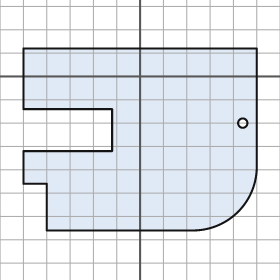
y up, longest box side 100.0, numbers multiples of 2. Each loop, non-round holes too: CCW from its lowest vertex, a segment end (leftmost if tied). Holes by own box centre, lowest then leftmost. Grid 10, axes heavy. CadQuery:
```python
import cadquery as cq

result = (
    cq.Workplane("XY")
    .moveTo(-40.0, -66.0)
    .lineTo(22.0, -66.0)
    .threePointArc((42.0, -58.0), (50.0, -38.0))
    .lineTo(50.0, 12.0)
    .lineTo(-50.0, 12.0)
    .lineTo(-50.0, -14.0)
    .lineTo(-12.0, -14.0)
    .lineTo(-12.0, -32.0)
    .lineTo(-50.0, -32.0)
    .lineTo(-50.0, -46.0)
    .lineTo(-40.0, -46.0)
    .close()
    .moveTo(44.0, -20.0)
    .circle(2.0)
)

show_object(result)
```